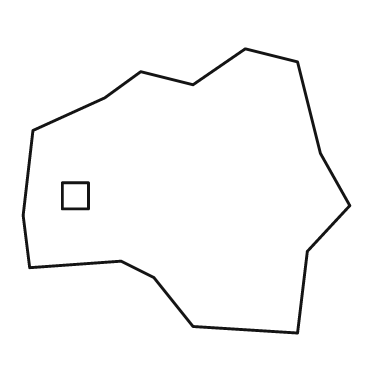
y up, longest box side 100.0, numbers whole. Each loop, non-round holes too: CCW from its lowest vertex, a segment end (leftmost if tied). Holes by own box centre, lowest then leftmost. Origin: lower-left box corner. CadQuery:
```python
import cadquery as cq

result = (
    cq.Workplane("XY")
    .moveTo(84.0, 0.0)
    .lineTo(87.0, 25.0)
    .lineTo(100.0, 39.0)
    .lineTo(91.0, 55.0)
    .lineTo(84.0, 83.0)
    .lineTo(68.0, 87.0)
    .lineTo(52.0, 76.0)
    .lineTo(36.0, 80.0)
    .lineTo(25.0, 72.0)
    .lineTo(3.0, 62.0)
    .lineTo(0.0, 36.0)
    .lineTo(2.0, 20.0)
    .lineTo(30.0, 22.0)
    .lineTo(40.0, 17.0)
    .lineTo(52.0, 2.0)
    .close()
    .moveTo(12.0, 38.0)
    .lineTo(20.0, 38.0)
    .lineTo(20.0, 46.0)
    .lineTo(12.0, 46.0)
    .close()
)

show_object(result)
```